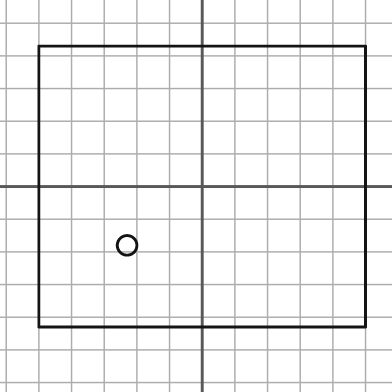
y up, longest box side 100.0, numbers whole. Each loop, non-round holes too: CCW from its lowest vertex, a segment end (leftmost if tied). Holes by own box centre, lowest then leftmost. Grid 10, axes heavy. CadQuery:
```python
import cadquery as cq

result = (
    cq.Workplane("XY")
    .moveTo(-50.0, -43.0)
    .lineTo(50.0, -43.0)
    .lineTo(50.0, 43.0)
    .lineTo(-50.0, 43.0)
    .close()
    .moveTo(-23.0, -18.0)
    .circle(3.0)
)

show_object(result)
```